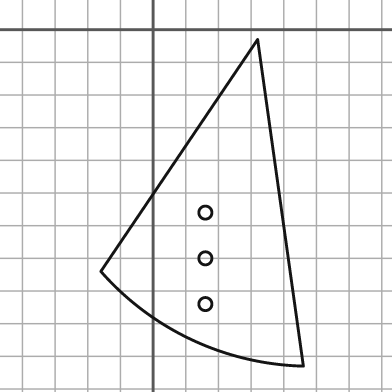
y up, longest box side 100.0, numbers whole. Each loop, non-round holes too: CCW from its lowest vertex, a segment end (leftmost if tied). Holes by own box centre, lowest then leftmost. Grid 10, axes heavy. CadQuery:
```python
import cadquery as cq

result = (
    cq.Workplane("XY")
    .moveTo(46.0, -103.0)
    .lineTo(32.0, -3.0)
    .lineTo(-16.0, -74.0)
    .threePointArc((12.0, -95.0), (46.0, -103.0))
    .close()
    .moveTo(16.0, -84.0)
    .circle(2.0)
    .moveTo(16.0, -70.0)
    .circle(2.0)
    .moveTo(16.0, -56.0)
    .circle(2.0)
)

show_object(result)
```